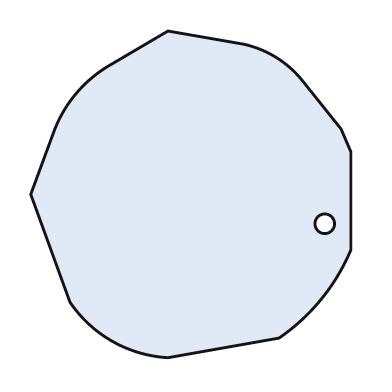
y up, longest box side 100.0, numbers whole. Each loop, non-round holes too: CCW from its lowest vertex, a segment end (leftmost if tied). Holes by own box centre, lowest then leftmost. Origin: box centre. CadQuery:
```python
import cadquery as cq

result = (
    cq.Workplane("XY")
    .moveTo(-7.0, -50.0)
    .lineTo(27.0, -44.0)
    .threePointArc((40.0, -32.0), (49.0, -17.0))
    .lineTo(49.0, 13.0)
    .lineTo(46.0, 20.0)
    .lineTo(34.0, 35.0)
    .threePointArc((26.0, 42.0), (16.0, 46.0))
    .lineTo(-7.0, 50.0)
    .lineTo(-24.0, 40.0)
    .threePointArc((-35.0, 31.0), (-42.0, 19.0))
    .lineTo(-49.0, 0.0)
    .lineTo(-37.0, -33.0)
    .threePointArc((-24.0, -45.0), (-7.0, -50.0))
    .close()
    .moveTo(41.0, -9.0)
    .circle(3.0)
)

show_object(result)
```